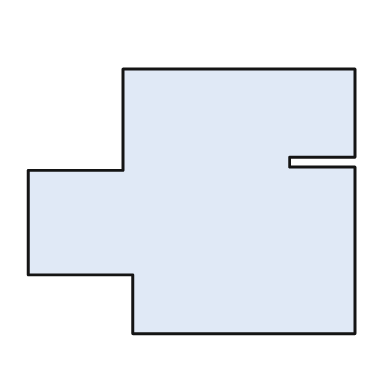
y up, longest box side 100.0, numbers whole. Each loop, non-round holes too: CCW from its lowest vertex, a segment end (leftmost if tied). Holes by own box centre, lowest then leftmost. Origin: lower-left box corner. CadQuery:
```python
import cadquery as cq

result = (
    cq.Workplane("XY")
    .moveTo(32.0, 0.0)
    .lineTo(100.0, 0.0)
    .lineTo(100.0, 51.0)
    .lineTo(80.0, 51.0)
    .lineTo(80.0, 54.0)
    .lineTo(100.0, 54.0)
    .lineTo(100.0, 81.0)
    .lineTo(29.0, 81.0)
    .lineTo(29.0, 50.0)
    .lineTo(0.0, 50.0)
    .lineTo(0.0, 18.0)
    .lineTo(32.0, 18.0)
    .close()
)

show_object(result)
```